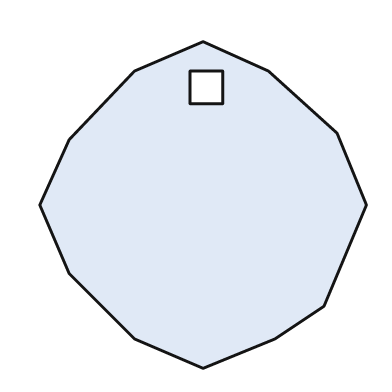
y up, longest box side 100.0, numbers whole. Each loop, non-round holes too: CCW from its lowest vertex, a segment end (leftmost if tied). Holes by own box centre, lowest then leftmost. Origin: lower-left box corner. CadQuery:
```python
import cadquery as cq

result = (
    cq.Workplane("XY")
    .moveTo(50.0, 0.0)
    .lineTo(72.0, 9.0)
    .lineTo(87.0, 19.0)
    .lineTo(100.0, 50.0)
    .lineTo(91.0, 72.0)
    .lineTo(70.0, 91.0)
    .lineTo(50.0, 100.0)
    .lineTo(29.0, 91.0)
    .lineTo(9.0, 70.0)
    .lineTo(0.0, 50.0)
    .lineTo(9.0, 29.0)
    .lineTo(29.0, 9.0)
    .close()
    .moveTo(46.0, 81.0)
    .lineTo(56.0, 81.0)
    .lineTo(56.0, 91.0)
    .lineTo(46.0, 91.0)
    .close()
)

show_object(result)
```